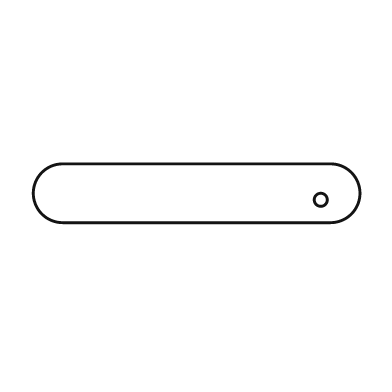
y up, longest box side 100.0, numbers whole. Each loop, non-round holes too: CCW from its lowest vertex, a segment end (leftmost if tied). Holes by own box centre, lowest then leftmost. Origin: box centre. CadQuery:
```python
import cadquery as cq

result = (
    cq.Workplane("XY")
    .moveTo(-41.0, -9.0)
    .lineTo(41.0, -9.0)
    .threePointArc((50.0, 0.0), (41.0, 9.0))
    .lineTo(-41.0, 9.0)
    .threePointArc((-50.0, 0.0), (-41.0, -9.0))
    .close()
    .moveTo(38.0, -2.0)
    .circle(2.0)
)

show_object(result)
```